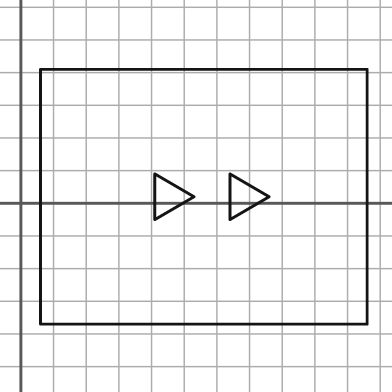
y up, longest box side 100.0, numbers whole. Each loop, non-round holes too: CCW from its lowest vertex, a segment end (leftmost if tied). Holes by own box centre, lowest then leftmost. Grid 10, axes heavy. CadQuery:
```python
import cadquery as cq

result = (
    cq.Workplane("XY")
    .moveTo(6.0, -37.0)
    .lineTo(106.0, -37.0)
    .lineTo(106.0, 41.0)
    .lineTo(6.0, 41.0)
    .close()
    .moveTo(41.0, -5.0)
    .lineTo(53.0, 2.0)
    .lineTo(41.0, 9.0)
    .close()
    .moveTo(64.0, -5.0)
    .lineTo(76.0, 2.0)
    .lineTo(64.0, 9.0)
    .close()
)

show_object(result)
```